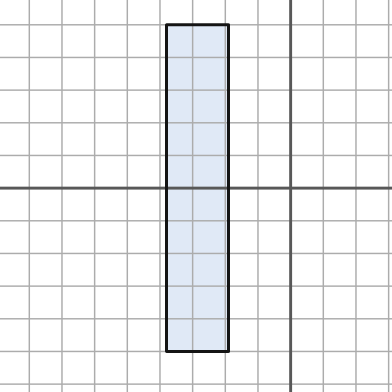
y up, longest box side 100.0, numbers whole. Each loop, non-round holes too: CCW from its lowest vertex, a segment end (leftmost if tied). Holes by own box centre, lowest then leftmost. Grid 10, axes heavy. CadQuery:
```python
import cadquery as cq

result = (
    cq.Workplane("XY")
    .moveTo(-38.0, -50.0)
    .lineTo(-19.0, -50.0)
    .lineTo(-19.0, 50.0)
    .lineTo(-38.0, 50.0)
    .close()
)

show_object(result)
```